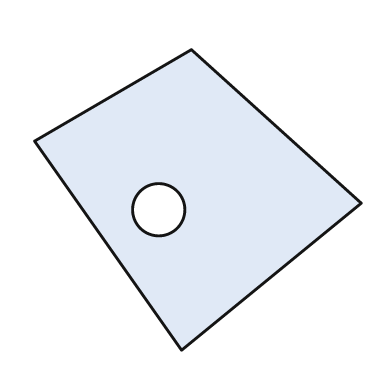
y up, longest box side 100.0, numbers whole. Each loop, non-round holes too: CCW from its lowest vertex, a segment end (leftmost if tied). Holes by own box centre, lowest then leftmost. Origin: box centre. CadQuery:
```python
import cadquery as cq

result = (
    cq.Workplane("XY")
    .moveTo(-5.0, -46.0)
    .lineTo(50.0, -1.0)
    .lineTo(-2.0, 46.0)
    .lineTo(-50.0, 18.0)
    .close()
    .moveTo(-12.0, -3.0)
    .circle(8.0)
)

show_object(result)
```